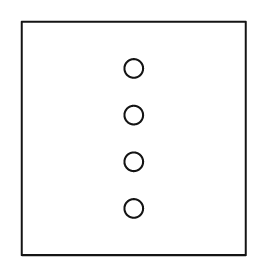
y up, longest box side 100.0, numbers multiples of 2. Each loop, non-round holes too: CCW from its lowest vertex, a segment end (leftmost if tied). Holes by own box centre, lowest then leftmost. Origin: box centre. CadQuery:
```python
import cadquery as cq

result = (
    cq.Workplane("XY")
    .moveTo(-48.0, -50.0)
    .lineTo(48.0, -50.0)
    .lineTo(48.0, 50.0)
    .lineTo(-48.0, 50.0)
    .close()
    .moveTo(0.0, -30.0)
    .circle(4.0)
    .moveTo(0.0, -10.0)
    .circle(4.0)
    .moveTo(0.0, 10.0)
    .circle(4.0)
    .moveTo(0.0, 30.0)
    .circle(4.0)
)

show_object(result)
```